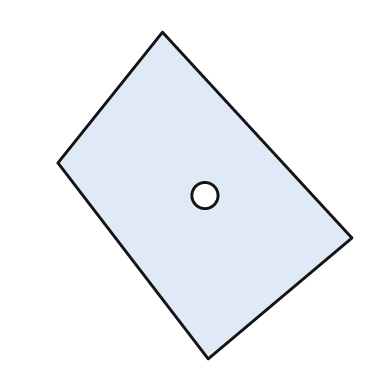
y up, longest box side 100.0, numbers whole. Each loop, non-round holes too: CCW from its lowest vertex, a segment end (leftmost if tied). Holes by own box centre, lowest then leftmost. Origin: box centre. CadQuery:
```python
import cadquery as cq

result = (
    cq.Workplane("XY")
    .moveTo(1.0, -50.0)
    .lineTo(45.0, -13.0)
    .lineTo(-13.0, 50.0)
    .lineTo(-45.0, 10.0)
    .close()
    .moveTo(0.0, 0.0)
    .circle(4.0)
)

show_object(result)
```